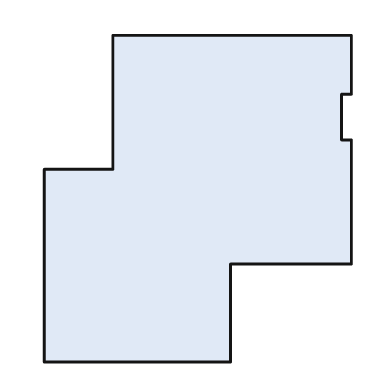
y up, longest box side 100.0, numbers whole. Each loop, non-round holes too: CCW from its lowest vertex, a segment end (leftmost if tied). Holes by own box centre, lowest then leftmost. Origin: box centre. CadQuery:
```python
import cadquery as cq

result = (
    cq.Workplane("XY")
    .moveTo(-47.0, -50.0)
    .lineTo(10.0, -50.0)
    .lineTo(10.0, -20.0)
    .lineTo(47.0, -20.0)
    .lineTo(47.0, 18.0)
    .lineTo(44.0, 18.0)
    .lineTo(44.0, 32.0)
    .lineTo(47.0, 32.0)
    .lineTo(47.0, 50.0)
    .lineTo(-26.0, 50.0)
    .lineTo(-26.0, 9.0)
    .lineTo(-47.0, 9.0)
    .close()
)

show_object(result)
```